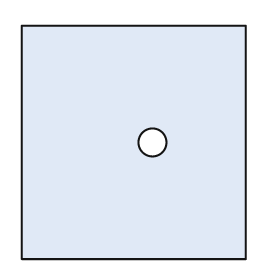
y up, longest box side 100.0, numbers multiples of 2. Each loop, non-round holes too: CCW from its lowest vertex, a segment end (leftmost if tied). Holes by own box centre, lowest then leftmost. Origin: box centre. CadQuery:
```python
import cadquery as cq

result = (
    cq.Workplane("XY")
    .moveTo(-48.0, -50.0)
    .lineTo(48.0, -50.0)
    .lineTo(48.0, 50.0)
    .lineTo(-48.0, 50.0)
    .close()
    .moveTo(8.0, 0.0)
    .circle(6.0)
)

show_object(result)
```